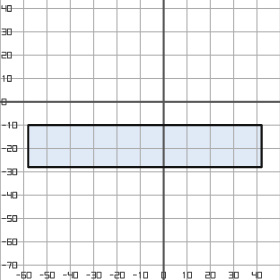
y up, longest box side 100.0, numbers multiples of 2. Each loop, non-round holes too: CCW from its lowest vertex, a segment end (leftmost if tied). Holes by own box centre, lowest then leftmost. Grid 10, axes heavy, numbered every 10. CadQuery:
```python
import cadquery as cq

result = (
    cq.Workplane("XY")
    .moveTo(-58.0, -28.0)
    .lineTo(42.0, -28.0)
    .lineTo(42.0, -10.0)
    .lineTo(-58.0, -10.0)
    .close()
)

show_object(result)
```